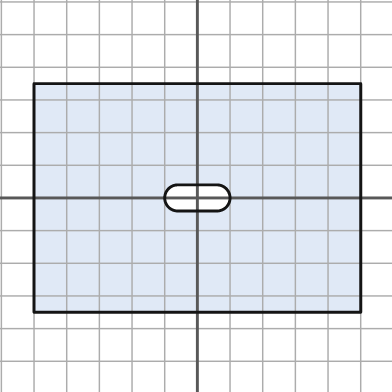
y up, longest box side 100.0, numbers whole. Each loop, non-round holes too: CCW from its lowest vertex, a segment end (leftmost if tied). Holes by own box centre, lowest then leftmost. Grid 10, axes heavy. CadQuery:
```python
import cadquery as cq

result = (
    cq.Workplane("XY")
    .moveTo(-50.0, -35.0)
    .lineTo(50.0, -35.0)
    .lineTo(50.0, 35.0)
    .lineTo(-50.0, 35.0)
    .close()
    .moveTo(-6.0, -4.0)
    .lineTo(6.0, -4.0)
    .threePointArc((10.0, 0.0), (6.0, 4.0))
    .lineTo(-6.0, 4.0)
    .threePointArc((-10.0, 0.0), (-6.0, -4.0))
    .close()
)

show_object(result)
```